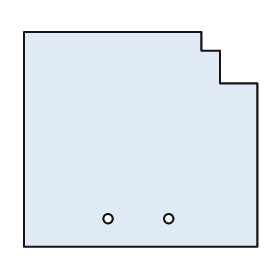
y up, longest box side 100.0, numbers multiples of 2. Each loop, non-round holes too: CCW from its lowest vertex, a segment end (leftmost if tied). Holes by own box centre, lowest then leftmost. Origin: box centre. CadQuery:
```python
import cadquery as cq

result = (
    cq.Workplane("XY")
    .moveTo(-50.0, -46.0)
    .lineTo(50.0, -46.0)
    .lineTo(50.0, 24.0)
    .lineTo(34.0, 24.0)
    .lineTo(34.0, 38.0)
    .lineTo(26.0, 38.0)
    .lineTo(26.0, 46.0)
    .lineTo(-50.0, 46.0)
    .close()
    .moveTo(-14.0, -34.0)
    .circle(2.0)
    .moveTo(12.0, -34.0)
    .circle(2.0)
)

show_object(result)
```